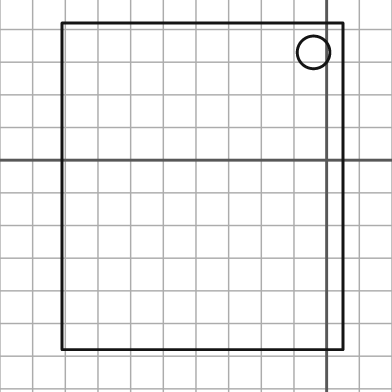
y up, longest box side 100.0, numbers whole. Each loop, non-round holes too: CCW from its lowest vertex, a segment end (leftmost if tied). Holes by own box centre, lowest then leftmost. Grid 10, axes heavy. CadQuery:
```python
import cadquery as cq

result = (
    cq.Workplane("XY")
    .moveTo(-81.0, -58.0)
    .lineTo(5.0, -58.0)
    .lineTo(5.0, 42.0)
    .lineTo(-81.0, 42.0)
    .close()
    .moveTo(-4.0, 33.0)
    .circle(5.0)
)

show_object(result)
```